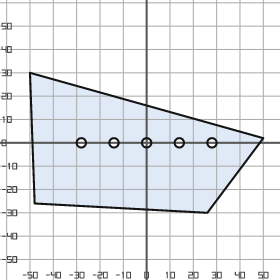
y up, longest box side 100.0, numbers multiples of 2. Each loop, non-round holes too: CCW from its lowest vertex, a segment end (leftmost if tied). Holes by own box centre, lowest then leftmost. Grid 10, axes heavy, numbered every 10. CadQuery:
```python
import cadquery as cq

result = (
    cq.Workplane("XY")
    .moveTo(26.0, -30.0)
    .lineTo(50.0, 2.0)
    .lineTo(-50.0, 30.0)
    .lineTo(-48.0, -26.0)
    .close()
    .moveTo(-28.0, 0.0)
    .circle(2.0)
    .moveTo(-14.0, 0.0)
    .circle(2.0)
    .moveTo(0.0, 0.0)
    .circle(2.0)
    .moveTo(14.0, 0.0)
    .circle(2.0)
    .moveTo(28.0, 0.0)
    .circle(2.0)
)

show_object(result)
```